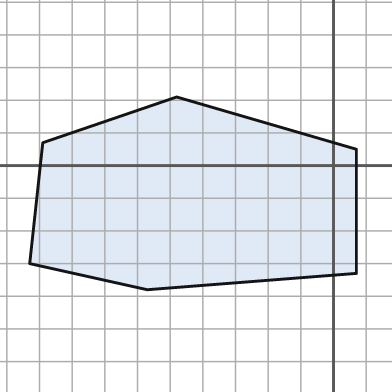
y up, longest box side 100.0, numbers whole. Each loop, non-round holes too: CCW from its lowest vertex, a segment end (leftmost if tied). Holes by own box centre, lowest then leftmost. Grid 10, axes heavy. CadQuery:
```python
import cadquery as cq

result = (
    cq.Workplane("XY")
    .moveTo(-57.0, -38.0)
    .lineTo(7.0, -33.0)
    .lineTo(7.0, 5.0)
    .lineTo(-48.0, 21.0)
    .lineTo(-89.0, 7.0)
    .lineTo(-93.0, -30.0)
    .close()
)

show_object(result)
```